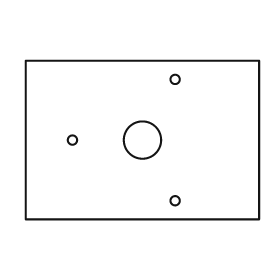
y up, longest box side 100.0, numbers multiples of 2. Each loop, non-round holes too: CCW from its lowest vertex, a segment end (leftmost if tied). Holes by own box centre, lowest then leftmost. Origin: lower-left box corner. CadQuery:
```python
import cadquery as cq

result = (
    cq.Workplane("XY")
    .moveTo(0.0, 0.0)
    .lineTo(100.0, 0.0)
    .lineTo(100.0, 68.0)
    .lineTo(0.0, 68.0)
    .close()
    .moveTo(64.0, 8.0)
    .circle(2.0)
    .moveTo(20.0, 34.0)
    .circle(2.0)
    .moveTo(50.0, 34.0)
    .circle(8.0)
    .moveTo(64.0, 60.0)
    .circle(2.0)
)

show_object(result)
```